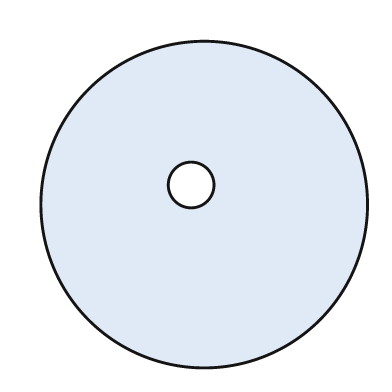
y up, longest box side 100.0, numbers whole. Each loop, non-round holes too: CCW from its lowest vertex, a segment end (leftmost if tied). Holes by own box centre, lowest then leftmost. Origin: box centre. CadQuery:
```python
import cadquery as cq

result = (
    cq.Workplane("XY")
    .moveTo(0.0, 0.0)
    .circle(50.0)
    .moveTo(-4.0, 6.0)
    .circle(7.0)
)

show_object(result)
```